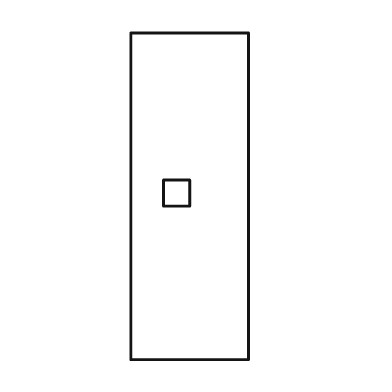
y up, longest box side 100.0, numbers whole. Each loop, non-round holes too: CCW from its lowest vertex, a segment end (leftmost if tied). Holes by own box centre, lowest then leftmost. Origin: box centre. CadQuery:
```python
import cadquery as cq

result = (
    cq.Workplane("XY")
    .moveTo(-18.0, -50.0)
    .lineTo(18.0, -50.0)
    .lineTo(18.0, 50.0)
    .lineTo(-18.0, 50.0)
    .close()
    .moveTo(-8.0, -3.0)
    .lineTo(0.0, -3.0)
    .lineTo(0.0, 5.0)
    .lineTo(-8.0, 5.0)
    .close()
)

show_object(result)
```